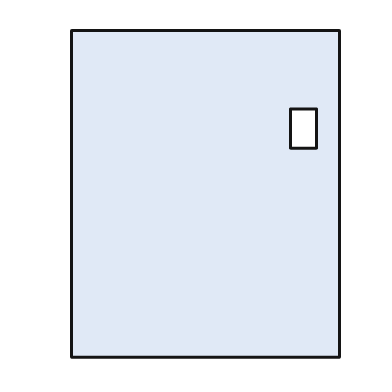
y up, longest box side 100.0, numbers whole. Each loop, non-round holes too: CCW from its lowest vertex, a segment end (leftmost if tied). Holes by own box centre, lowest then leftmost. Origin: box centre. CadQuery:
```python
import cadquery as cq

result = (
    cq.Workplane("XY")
    .moveTo(-41.0, -50.0)
    .lineTo(41.0, -50.0)
    .lineTo(41.0, 50.0)
    .lineTo(-41.0, 50.0)
    .close()
    .moveTo(26.0, 14.0)
    .lineTo(34.0, 14.0)
    .lineTo(34.0, 26.0)
    .lineTo(26.0, 26.0)
    .close()
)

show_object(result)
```